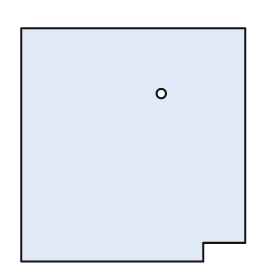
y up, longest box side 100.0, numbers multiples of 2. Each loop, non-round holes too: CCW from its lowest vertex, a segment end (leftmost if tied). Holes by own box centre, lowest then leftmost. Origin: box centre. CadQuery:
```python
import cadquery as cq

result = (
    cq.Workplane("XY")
    .moveTo(-48.0, -50.0)
    .lineTo(30.0, -50.0)
    .lineTo(30.0, -42.0)
    .lineTo(48.0, -42.0)
    .lineTo(48.0, 50.0)
    .lineTo(-48.0, 50.0)
    .close()
    .moveTo(12.0, 22.0)
    .circle(2.0)
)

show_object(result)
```